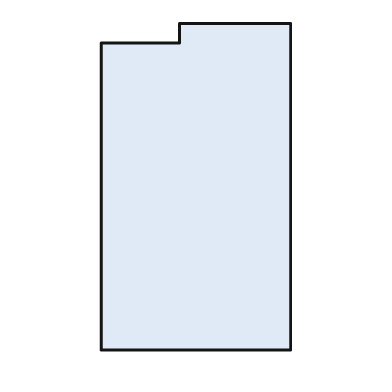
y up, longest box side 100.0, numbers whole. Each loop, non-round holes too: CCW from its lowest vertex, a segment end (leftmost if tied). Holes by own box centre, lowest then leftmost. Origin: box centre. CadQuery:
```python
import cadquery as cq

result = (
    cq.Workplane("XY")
    .moveTo(-29.0, -50.0)
    .lineTo(29.0, -50.0)
    .lineTo(29.0, 50.0)
    .lineTo(-5.0, 50.0)
    .lineTo(-5.0, 44.0)
    .lineTo(-29.0, 44.0)
    .close()
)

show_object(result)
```